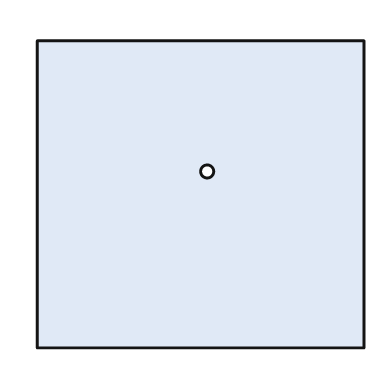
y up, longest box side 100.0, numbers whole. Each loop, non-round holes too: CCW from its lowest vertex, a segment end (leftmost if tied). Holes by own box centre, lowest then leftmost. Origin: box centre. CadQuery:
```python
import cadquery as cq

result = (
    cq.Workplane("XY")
    .moveTo(-50.0, -47.0)
    .lineTo(50.0, -47.0)
    .lineTo(50.0, 47.0)
    .lineTo(-50.0, 47.0)
    .close()
    .moveTo(2.0, 7.0)
    .circle(2.0)
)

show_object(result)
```